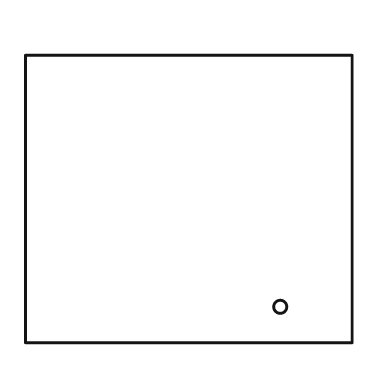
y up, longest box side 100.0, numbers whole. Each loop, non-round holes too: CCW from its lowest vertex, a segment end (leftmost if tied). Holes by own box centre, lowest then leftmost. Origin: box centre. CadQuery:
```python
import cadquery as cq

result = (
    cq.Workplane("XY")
    .moveTo(-50.0, -44.0)
    .lineTo(50.0, -44.0)
    .lineTo(50.0, 44.0)
    .lineTo(-50.0, 44.0)
    .close()
    .moveTo(28.0, -33.0)
    .circle(2.0)
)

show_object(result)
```